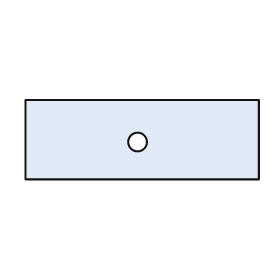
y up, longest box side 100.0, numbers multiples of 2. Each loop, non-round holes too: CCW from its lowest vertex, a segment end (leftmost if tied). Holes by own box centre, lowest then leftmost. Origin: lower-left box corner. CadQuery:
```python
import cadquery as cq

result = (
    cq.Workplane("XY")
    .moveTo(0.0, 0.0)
    .lineTo(100.0, 0.0)
    .lineTo(100.0, 34.0)
    .lineTo(0.0, 34.0)
    .close()
    .moveTo(48.0, 16.0)
    .circle(4.0)
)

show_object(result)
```